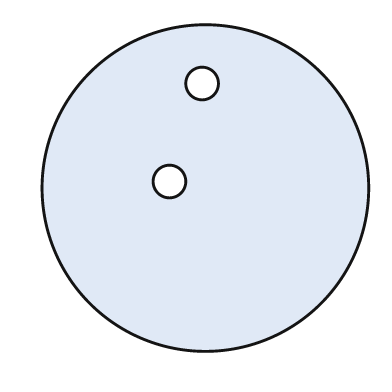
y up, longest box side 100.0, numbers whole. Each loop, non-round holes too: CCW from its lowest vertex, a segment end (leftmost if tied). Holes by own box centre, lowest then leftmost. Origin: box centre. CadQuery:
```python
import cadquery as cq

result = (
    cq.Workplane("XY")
    .moveTo(0.0, 0.0)
    .circle(50.0)
    .moveTo(-11.0, 2.0)
    .circle(5.0)
    .moveTo(-1.0, 32.0)
    .circle(5.0)
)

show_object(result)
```